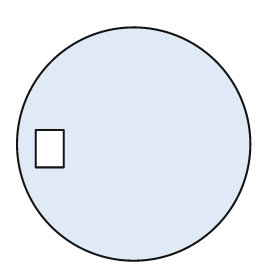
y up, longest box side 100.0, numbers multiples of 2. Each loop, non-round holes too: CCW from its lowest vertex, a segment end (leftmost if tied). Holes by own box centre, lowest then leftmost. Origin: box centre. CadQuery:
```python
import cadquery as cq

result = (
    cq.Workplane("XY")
    .moveTo(0.0, 0.0)
    .circle(50.0)
    .moveTo(-42.0, -10.0)
    .lineTo(-30.0, -10.0)
    .lineTo(-30.0, 6.0)
    .lineTo(-42.0, 6.0)
    .close()
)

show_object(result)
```